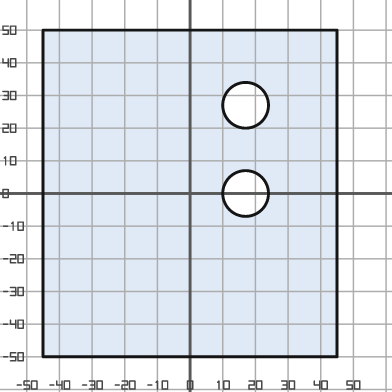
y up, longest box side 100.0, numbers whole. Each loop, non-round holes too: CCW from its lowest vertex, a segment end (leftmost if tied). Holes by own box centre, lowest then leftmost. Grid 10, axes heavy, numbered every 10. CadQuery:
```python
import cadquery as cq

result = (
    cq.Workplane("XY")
    .moveTo(-45.0, -50.0)
    .lineTo(45.0, -50.0)
    .lineTo(45.0, 50.0)
    .lineTo(-45.0, 50.0)
    .close()
    .moveTo(17.0, 0.0)
    .circle(7.0)
    .moveTo(17.0, 27.0)
    .circle(7.0)
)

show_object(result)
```